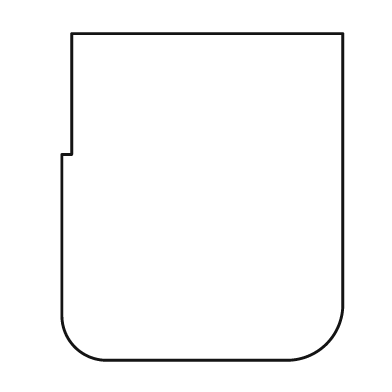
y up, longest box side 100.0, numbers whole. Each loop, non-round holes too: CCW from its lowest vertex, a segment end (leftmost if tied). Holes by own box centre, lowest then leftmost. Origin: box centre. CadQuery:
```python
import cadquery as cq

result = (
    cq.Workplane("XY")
    .moveTo(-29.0, -50.0)
    .lineTo(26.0, -50.0)
    .threePointArc((38.0, -45.0), (43.0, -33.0))
    .lineTo(43.0, 50.0)
    .lineTo(-40.0, 50.0)
    .lineTo(-40.0, 13.0)
    .lineTo(-43.0, 13.0)
    .lineTo(-43.0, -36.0)
    .threePointArc((-39.0, -46.0), (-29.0, -50.0))
    .close()
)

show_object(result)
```